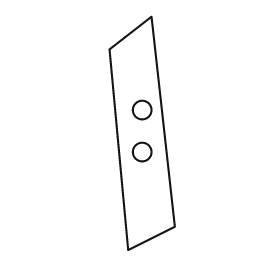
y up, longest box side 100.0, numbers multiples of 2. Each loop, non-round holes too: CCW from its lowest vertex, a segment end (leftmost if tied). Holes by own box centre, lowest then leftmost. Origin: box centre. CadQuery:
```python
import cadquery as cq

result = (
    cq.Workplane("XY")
    .moveTo(-6.0, -50.0)
    .lineTo(14.0, -40.0)
    .lineTo(4.0, 50.0)
    .lineTo(-14.0, 36.0)
    .close()
    .moveTo(0.0, -8.0)
    .circle(4.0)
    .moveTo(0.0, 10.0)
    .circle(4.0)
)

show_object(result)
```